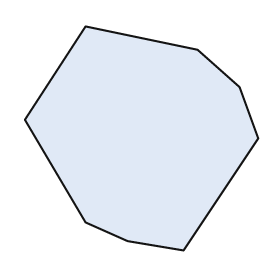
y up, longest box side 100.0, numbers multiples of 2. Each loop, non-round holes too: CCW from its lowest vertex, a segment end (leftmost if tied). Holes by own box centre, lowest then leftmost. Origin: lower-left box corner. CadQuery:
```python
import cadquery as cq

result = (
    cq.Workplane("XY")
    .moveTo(68.0, 0.0)
    .lineTo(100.0, 48.0)
    .lineTo(92.0, 70.0)
    .lineTo(74.0, 86.0)
    .lineTo(26.0, 96.0)
    .lineTo(0.0, 56.0)
    .lineTo(26.0, 12.0)
    .lineTo(44.0, 4.0)
    .close()
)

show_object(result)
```